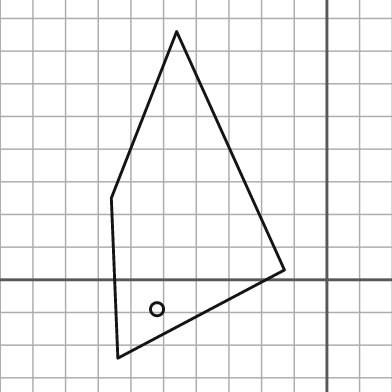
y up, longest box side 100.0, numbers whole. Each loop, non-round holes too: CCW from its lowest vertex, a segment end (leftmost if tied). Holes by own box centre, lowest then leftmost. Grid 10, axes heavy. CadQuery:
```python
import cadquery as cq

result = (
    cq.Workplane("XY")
    .moveTo(-64.0, -24.0)
    .lineTo(-13.0, 3.0)
    .lineTo(-46.0, 76.0)
    .lineTo(-66.0, 25.0)
    .close()
    .moveTo(-52.0, -9.0)
    .circle(2.0)
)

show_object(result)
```